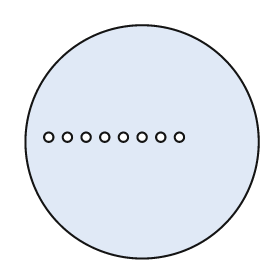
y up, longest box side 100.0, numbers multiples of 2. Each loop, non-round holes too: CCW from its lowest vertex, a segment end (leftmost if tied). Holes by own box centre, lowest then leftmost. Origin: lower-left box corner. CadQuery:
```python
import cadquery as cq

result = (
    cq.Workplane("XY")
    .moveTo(50.0, 50.0)
    .circle(50.0)
    .moveTo(10.0, 52.0)
    .circle(2.0)
    .moveTo(18.0, 52.0)
    .circle(2.0)
    .moveTo(26.0, 52.0)
    .circle(2.0)
    .moveTo(34.0, 52.0)
    .circle(2.0)
    .moveTo(42.0, 52.0)
    .circle(2.0)
    .moveTo(50.0, 52.0)
    .circle(2.0)
    .moveTo(58.0, 52.0)
    .circle(2.0)
    .moveTo(66.0, 52.0)
    .circle(2.0)
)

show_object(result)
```